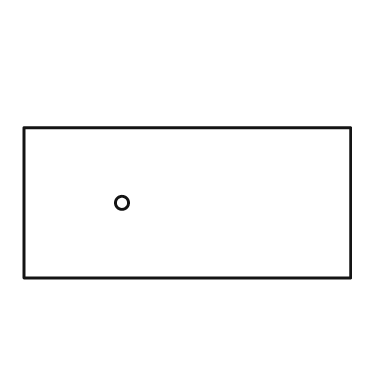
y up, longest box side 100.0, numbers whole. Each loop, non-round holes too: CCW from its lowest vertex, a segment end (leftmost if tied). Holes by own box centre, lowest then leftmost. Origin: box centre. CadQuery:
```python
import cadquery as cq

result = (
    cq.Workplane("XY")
    .moveTo(-50.0, -23.0)
    .lineTo(50.0, -23.0)
    .lineTo(50.0, 23.0)
    .lineTo(-50.0, 23.0)
    .close()
    .moveTo(-20.0, 0.0)
    .circle(2.0)
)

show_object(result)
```